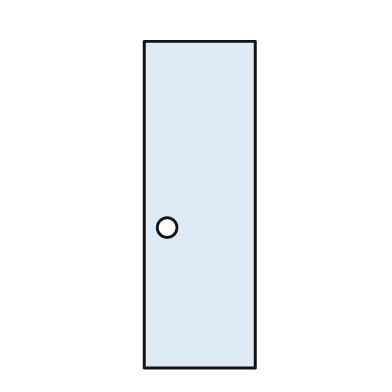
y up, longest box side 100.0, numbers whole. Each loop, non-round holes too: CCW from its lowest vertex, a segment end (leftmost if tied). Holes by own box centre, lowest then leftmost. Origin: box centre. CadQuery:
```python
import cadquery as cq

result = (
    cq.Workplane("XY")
    .moveTo(-17.0, -50.0)
    .lineTo(17.0, -50.0)
    .lineTo(17.0, 50.0)
    .lineTo(-17.0, 50.0)
    .close()
    .moveTo(-10.0, -7.0)
    .circle(3.0)
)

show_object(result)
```